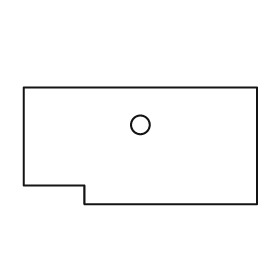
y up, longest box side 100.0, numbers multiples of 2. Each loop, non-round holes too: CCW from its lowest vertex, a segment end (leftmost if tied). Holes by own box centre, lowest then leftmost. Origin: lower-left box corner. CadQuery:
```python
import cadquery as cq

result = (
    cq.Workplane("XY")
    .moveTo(26.0, 0.0)
    .lineTo(100.0, 0.0)
    .lineTo(100.0, 50.0)
    .lineTo(0.0, 50.0)
    .lineTo(0.0, 8.0)
    .lineTo(26.0, 8.0)
    .close()
    .moveTo(50.0, 34.0)
    .circle(4.0)
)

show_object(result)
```